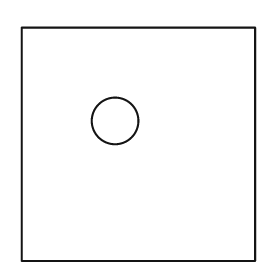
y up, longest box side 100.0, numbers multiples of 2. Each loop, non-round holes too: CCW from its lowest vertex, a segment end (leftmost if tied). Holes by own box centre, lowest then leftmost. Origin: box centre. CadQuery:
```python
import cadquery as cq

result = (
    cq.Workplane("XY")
    .moveTo(-50.0, -50.0)
    .lineTo(50.0, -50.0)
    .lineTo(50.0, 50.0)
    .lineTo(-50.0, 50.0)
    .close()
    .moveTo(-10.0, 10.0)
    .circle(10.0)
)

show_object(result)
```